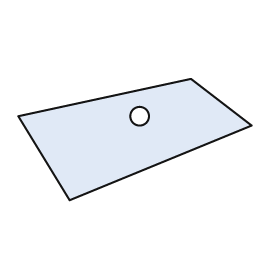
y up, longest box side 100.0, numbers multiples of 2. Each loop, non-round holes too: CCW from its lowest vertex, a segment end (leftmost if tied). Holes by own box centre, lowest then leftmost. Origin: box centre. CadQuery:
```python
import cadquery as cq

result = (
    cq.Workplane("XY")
    .moveTo(-28.0, -26.0)
    .lineTo(50.0, 6.0)
    .lineTo(24.0, 26.0)
    .lineTo(-50.0, 10.0)
    .close()
    .moveTo(2.0, 10.0)
    .circle(4.0)
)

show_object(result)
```